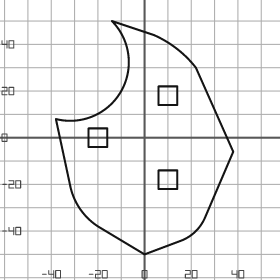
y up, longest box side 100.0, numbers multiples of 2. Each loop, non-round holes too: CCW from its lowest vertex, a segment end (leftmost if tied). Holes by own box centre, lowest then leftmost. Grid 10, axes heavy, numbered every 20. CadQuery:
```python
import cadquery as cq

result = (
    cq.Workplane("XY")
    .moveTo(0.0, -50.0)
    .lineTo(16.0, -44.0)
    .threePointArc((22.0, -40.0), (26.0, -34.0))
    .lineTo(38.0, -6.0)
    .lineTo(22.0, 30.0)
    .threePointArc((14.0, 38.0), (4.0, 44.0))
    .lineTo(-14.0, 50.0)
    .threePointArc((-10.0, 20.0), (-38.0, 8.0))
    .lineTo(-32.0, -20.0)
    .threePointArc((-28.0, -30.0), (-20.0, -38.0))
    .close()
    .moveTo(6.0, -22.0)
    .lineTo(14.0, -22.0)
    .lineTo(14.0, -14.0)
    .lineTo(6.0, -14.0)
    .close()
    .moveTo(-24.0, -4.0)
    .lineTo(-16.0, -4.0)
    .lineTo(-16.0, 4.0)
    .lineTo(-24.0, 4.0)
    .close()
    .moveTo(6.0, 14.0)
    .lineTo(14.0, 14.0)
    .lineTo(14.0, 22.0)
    .lineTo(6.0, 22.0)
    .close()
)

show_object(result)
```